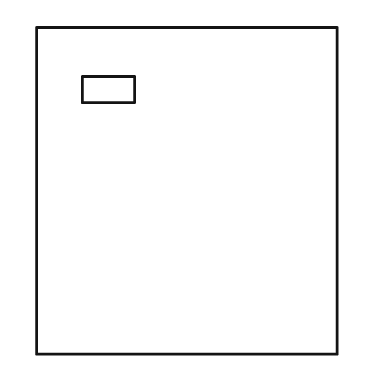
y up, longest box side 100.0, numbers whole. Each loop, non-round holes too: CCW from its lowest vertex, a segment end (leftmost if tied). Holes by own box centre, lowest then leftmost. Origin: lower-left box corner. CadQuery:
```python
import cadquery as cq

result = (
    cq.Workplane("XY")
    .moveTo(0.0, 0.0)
    .lineTo(92.0, 0.0)
    .lineTo(92.0, 100.0)
    .lineTo(0.0, 100.0)
    .close()
    .moveTo(14.0, 77.0)
    .lineTo(30.0, 77.0)
    .lineTo(30.0, 85.0)
    .lineTo(14.0, 85.0)
    .close()
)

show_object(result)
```